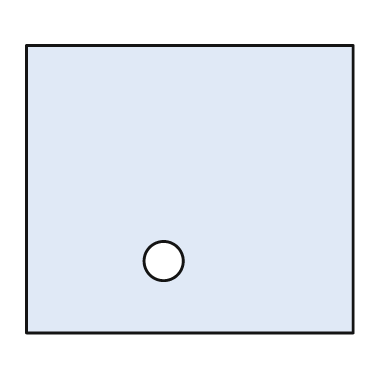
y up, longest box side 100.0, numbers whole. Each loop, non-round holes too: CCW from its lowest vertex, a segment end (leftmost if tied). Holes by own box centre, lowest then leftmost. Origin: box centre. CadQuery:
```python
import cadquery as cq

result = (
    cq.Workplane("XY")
    .moveTo(-50.0, -44.0)
    .lineTo(50.0, -44.0)
    .lineTo(50.0, 44.0)
    .lineTo(-50.0, 44.0)
    .close()
    .moveTo(-8.0, -22.0)
    .circle(6.0)
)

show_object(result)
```